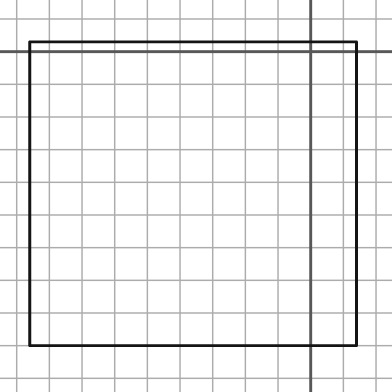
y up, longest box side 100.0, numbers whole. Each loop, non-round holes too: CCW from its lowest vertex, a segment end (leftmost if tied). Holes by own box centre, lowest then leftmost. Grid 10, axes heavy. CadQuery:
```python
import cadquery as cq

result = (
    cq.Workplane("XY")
    .moveTo(-86.0, -90.0)
    .lineTo(14.0, -90.0)
    .lineTo(14.0, 3.0)
    .lineTo(-86.0, 3.0)
    .close()
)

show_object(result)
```